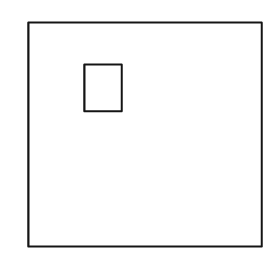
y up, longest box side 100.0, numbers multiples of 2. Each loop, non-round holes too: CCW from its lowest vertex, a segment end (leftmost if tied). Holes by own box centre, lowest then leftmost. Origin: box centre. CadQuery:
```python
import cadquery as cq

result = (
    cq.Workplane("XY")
    .moveTo(-50.0, -48.0)
    .lineTo(50.0, -48.0)
    .lineTo(50.0, 48.0)
    .lineTo(-50.0, 48.0)
    .close()
    .moveTo(-26.0, 10.0)
    .lineTo(-10.0, 10.0)
    .lineTo(-10.0, 30.0)
    .lineTo(-26.0, 30.0)
    .close()
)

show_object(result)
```